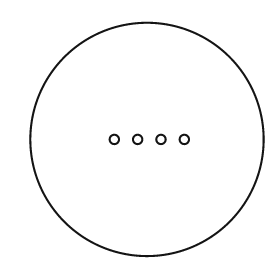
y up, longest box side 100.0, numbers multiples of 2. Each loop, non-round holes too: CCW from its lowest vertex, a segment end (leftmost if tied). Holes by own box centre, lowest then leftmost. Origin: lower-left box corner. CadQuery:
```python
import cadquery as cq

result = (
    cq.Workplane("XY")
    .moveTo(50.0, 50.0)
    .circle(50.0)
    .moveTo(36.0, 50.0)
    .circle(2.0)
    .moveTo(46.0, 50.0)
    .circle(2.0)
    .moveTo(56.0, 50.0)
    .circle(2.0)
    .moveTo(66.0, 50.0)
    .circle(2.0)
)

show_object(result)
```